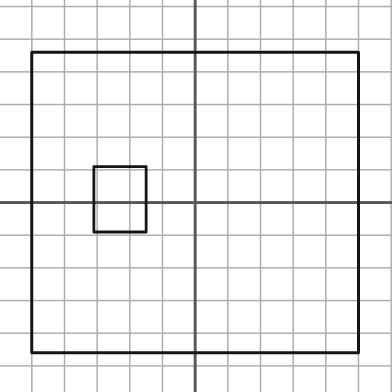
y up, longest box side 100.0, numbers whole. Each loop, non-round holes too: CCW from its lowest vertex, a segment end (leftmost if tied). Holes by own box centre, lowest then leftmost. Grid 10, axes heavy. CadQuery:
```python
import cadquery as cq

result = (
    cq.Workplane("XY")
    .moveTo(-50.0, -46.0)
    .lineTo(50.0, -46.0)
    .lineTo(50.0, 46.0)
    .lineTo(-50.0, 46.0)
    .close()
    .moveTo(-31.0, -9.0)
    .lineTo(-15.0, -9.0)
    .lineTo(-15.0, 11.0)
    .lineTo(-31.0, 11.0)
    .close()
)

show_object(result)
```